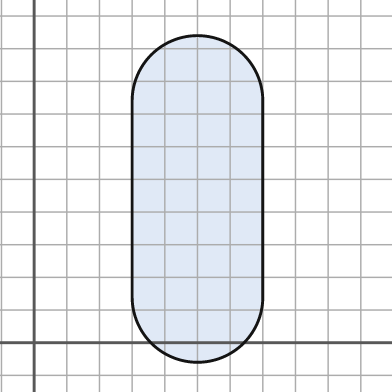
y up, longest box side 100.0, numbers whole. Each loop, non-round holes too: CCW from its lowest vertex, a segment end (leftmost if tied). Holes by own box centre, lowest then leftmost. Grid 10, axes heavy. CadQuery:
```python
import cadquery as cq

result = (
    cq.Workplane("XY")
    .moveTo(30.0, 14.0)
    .threePointArc((50.0, -6.0), (70.0, 14.0))
    .lineTo(70.0, 74.0)
    .threePointArc((50.0, 94.0), (30.0, 74.0))
    .close()
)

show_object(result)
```